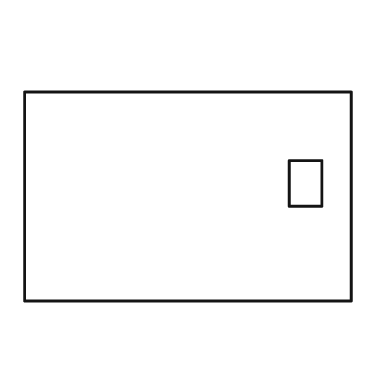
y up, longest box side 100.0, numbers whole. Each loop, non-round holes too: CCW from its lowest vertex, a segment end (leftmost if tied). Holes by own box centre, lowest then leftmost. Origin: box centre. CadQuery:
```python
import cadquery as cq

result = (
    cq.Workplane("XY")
    .moveTo(-50.0, -32.0)
    .lineTo(50.0, -32.0)
    .lineTo(50.0, 32.0)
    .lineTo(-50.0, 32.0)
    .close()
    .moveTo(31.0, -3.0)
    .lineTo(41.0, -3.0)
    .lineTo(41.0, 11.0)
    .lineTo(31.0, 11.0)
    .close()
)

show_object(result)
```